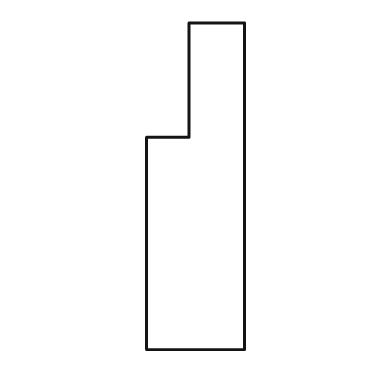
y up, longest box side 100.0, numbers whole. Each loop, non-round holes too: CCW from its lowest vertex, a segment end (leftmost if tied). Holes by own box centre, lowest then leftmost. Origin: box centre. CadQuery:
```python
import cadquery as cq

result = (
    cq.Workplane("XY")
    .moveTo(-15.0, -50.0)
    .lineTo(15.0, -50.0)
    .lineTo(15.0, 50.0)
    .lineTo(-2.0, 50.0)
    .lineTo(-2.0, 15.0)
    .lineTo(-15.0, 15.0)
    .close()
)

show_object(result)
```